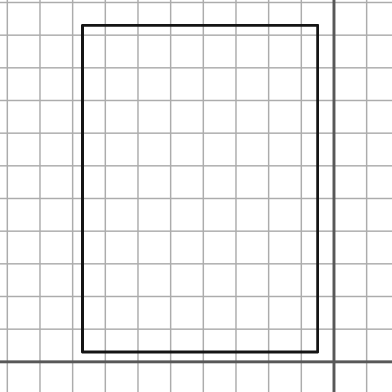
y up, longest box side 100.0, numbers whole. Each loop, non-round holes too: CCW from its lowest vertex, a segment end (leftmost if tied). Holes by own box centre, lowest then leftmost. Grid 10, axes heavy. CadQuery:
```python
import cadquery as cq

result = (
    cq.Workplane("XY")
    .moveTo(-77.0, 3.0)
    .lineTo(-5.0, 3.0)
    .lineTo(-5.0, 103.0)
    .lineTo(-77.0, 103.0)
    .close()
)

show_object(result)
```